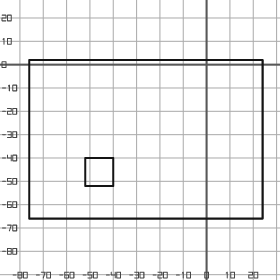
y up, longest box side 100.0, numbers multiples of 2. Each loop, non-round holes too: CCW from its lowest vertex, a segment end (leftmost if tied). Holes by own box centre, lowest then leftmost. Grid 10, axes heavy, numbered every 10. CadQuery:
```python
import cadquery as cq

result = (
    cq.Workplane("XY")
    .moveTo(-76.0, -66.0)
    .lineTo(24.0, -66.0)
    .lineTo(24.0, 2.0)
    .lineTo(-76.0, 2.0)
    .close()
    .moveTo(-52.0, -52.0)
    .lineTo(-40.0, -52.0)
    .lineTo(-40.0, -40.0)
    .lineTo(-52.0, -40.0)
    .close()
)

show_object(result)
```